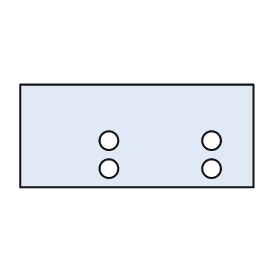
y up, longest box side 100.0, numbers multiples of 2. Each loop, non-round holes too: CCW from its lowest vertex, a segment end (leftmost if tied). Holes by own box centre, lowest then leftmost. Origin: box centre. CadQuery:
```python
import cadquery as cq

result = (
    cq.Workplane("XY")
    .moveTo(-50.0, -22.0)
    .lineTo(50.0, -22.0)
    .lineTo(50.0, 22.0)
    .lineTo(-50.0, 22.0)
    .close()
    .moveTo(-12.0, -14.0)
    .circle(4.0)
    .moveTo(32.0, -14.0)
    .circle(4.0)
    .moveTo(-12.0, -2.0)
    .circle(4.0)
    .moveTo(32.0, -2.0)
    .circle(4.0)
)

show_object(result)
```